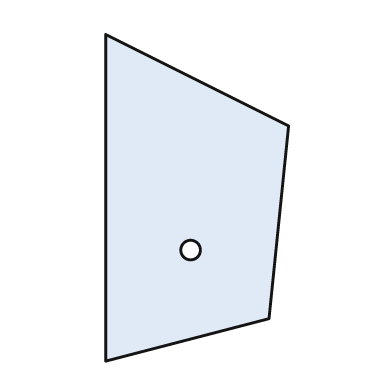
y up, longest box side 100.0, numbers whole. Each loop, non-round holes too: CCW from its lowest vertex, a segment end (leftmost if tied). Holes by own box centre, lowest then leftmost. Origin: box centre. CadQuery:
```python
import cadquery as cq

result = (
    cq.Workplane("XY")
    .moveTo(-28.0, -50.0)
    .lineTo(22.0, -37.0)
    .lineTo(28.0, 22.0)
    .lineTo(-28.0, 50.0)
    .close()
    .moveTo(-2.0, -16.0)
    .circle(3.0)
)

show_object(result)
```